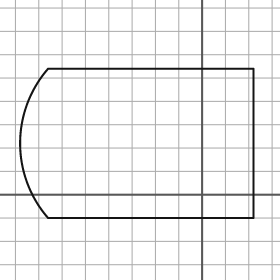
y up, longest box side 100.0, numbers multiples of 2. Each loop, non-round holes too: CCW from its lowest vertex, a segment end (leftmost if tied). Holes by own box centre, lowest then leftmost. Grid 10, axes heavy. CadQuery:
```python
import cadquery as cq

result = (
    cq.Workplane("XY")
    .moveTo(-66.0, -10.0)
    .lineTo(22.0, -10.0)
    .lineTo(22.0, 54.0)
    .lineTo(-66.0, 54.0)
    .threePointArc((-78.0, 22.0), (-66.0, -10.0))
    .close()
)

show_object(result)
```